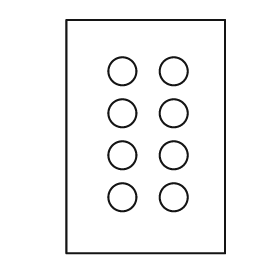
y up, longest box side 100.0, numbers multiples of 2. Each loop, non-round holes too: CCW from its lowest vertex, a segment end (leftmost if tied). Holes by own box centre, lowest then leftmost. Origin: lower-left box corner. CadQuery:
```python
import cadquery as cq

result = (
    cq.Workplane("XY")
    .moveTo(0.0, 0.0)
    .lineTo(68.0, 0.0)
    .lineTo(68.0, 100.0)
    .lineTo(0.0, 100.0)
    .close()
    .moveTo(24.0, 24.0)
    .circle(6.0)
    .moveTo(46.0, 24.0)
    .circle(6.0)
    .moveTo(24.0, 42.0)
    .circle(6.0)
    .moveTo(46.0, 42.0)
    .circle(6.0)
    .moveTo(24.0, 60.0)
    .circle(6.0)
    .moveTo(46.0, 60.0)
    .circle(6.0)
    .moveTo(24.0, 78.0)
    .circle(6.0)
    .moveTo(46.0, 78.0)
    .circle(6.0)
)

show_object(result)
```